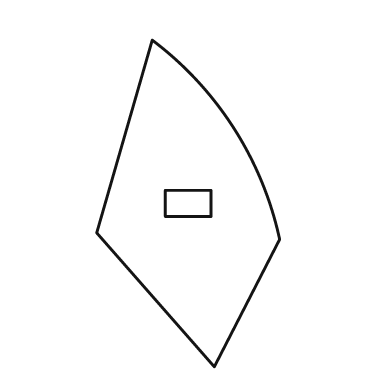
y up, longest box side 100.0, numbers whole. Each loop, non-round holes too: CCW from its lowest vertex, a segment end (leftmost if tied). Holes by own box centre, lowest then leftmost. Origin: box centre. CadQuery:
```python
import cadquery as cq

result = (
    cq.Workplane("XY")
    .moveTo(8.0, -50.0)
    .lineTo(28.0, -11.0)
    .threePointArc((14.0, 23.0), (-11.0, 50.0))
    .lineTo(-28.0, -9.0)
    .close()
    .moveTo(-7.0, -4.0)
    .lineTo(7.0, -4.0)
    .lineTo(7.0, 4.0)
    .lineTo(-7.0, 4.0)
    .close()
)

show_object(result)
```